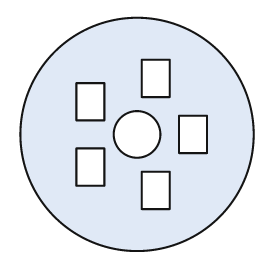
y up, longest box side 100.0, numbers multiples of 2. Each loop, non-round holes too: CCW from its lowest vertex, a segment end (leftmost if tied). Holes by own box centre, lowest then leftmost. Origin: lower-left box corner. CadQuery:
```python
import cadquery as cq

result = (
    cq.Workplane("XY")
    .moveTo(50.0, 50.0)
    .circle(50.0)
    .moveTo(52.0, 18.0)
    .lineTo(64.0, 18.0)
    .lineTo(64.0, 34.0)
    .lineTo(52.0, 34.0)
    .close()
    .moveTo(24.0, 28.0)
    .lineTo(36.0, 28.0)
    .lineTo(36.0, 44.0)
    .lineTo(24.0, 44.0)
    .close()
    .moveTo(50.0, 50.0)
    .circle(10.0)
    .moveTo(68.0, 42.0)
    .lineTo(80.0, 42.0)
    .lineTo(80.0, 58.0)
    .lineTo(68.0, 58.0)
    .close()
    .moveTo(24.0, 56.0)
    .lineTo(36.0, 56.0)
    .lineTo(36.0, 72.0)
    .lineTo(24.0, 72.0)
    .close()
    .moveTo(52.0, 66.0)
    .lineTo(64.0, 66.0)
    .lineTo(64.0, 82.0)
    .lineTo(52.0, 82.0)
    .close()
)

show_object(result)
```